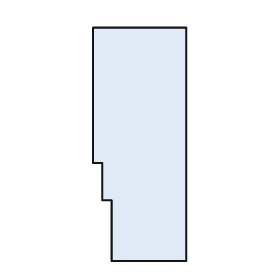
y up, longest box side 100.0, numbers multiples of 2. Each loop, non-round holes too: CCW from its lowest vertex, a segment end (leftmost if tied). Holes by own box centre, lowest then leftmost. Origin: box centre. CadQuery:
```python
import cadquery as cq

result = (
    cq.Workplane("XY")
    .moveTo(-12.0, -50.0)
    .lineTo(20.0, -50.0)
    .lineTo(20.0, 50.0)
    .lineTo(-20.0, 50.0)
    .lineTo(-20.0, -8.0)
    .lineTo(-16.0, -8.0)
    .lineTo(-16.0, -24.0)
    .lineTo(-12.0, -24.0)
    .close()
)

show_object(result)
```